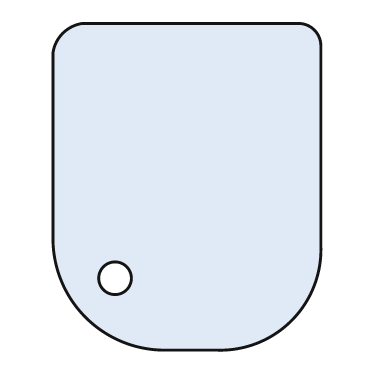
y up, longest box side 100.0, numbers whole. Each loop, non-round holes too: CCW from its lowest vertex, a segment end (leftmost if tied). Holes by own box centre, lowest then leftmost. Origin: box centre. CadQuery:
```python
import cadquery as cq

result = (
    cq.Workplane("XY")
    .moveTo(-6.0, -50.0)
    .lineTo(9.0, -50.0)
    .threePointArc((32.0, -41.0), (41.0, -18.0))
    .lineTo(41.0, 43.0)
    .threePointArc((39.0, 48.0), (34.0, 50.0))
    .lineTo(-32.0, 50.0)
    .threePointArc((-38.0, 47.0), (-41.0, 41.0))
    .lineTo(-41.0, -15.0)
    .threePointArc((-31.0, -40.0), (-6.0, -50.0))
    .close()
    .moveTo(-22.0, -28.0)
    .circle(5.0)
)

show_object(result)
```